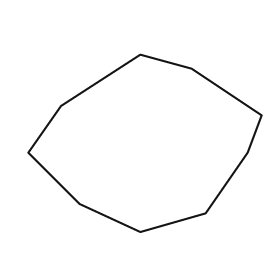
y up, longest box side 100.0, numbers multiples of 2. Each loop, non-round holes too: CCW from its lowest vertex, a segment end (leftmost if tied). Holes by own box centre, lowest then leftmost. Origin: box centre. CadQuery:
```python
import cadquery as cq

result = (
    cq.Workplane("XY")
    .moveTo(-2.0, -38.0)
    .lineTo(26.0, -30.0)
    .lineTo(44.0, -4.0)
    .lineTo(50.0, 12.0)
    .lineTo(20.0, 32.0)
    .lineTo(-2.0, 38.0)
    .lineTo(-36.0, 16.0)
    .lineTo(-50.0, -4.0)
    .lineTo(-28.0, -26.0)
    .close()
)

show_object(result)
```